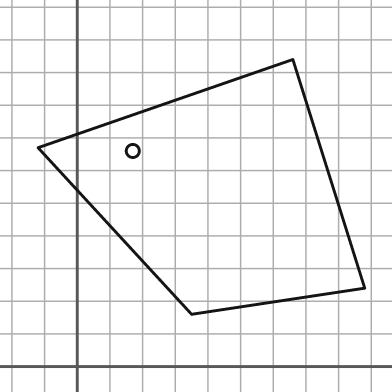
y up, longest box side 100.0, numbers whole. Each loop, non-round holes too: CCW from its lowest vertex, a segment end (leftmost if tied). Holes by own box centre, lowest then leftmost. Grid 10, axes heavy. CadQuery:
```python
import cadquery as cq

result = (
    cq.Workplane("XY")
    .moveTo(35.0, 16.0)
    .lineTo(88.0, 24.0)
    .lineTo(66.0, 94.0)
    .lineTo(-12.0, 67.0)
    .close()
    .moveTo(17.0, 66.0)
    .circle(2.0)
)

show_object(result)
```